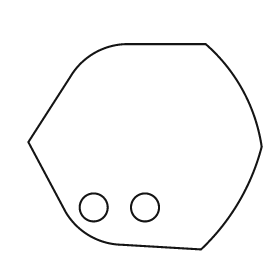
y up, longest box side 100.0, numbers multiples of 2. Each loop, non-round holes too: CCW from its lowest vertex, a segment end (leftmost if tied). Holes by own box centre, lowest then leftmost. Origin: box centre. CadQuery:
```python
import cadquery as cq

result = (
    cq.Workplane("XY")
    .moveTo(24.0, -44.0)
    .threePointArc((40.0, -24.0), (50.0, 0.0))
    .threePointArc((42.0, 24.0), (26.0, 44.0))
    .lineTo(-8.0, 44.0)
    .threePointArc((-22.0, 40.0), (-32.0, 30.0))
    .lineTo(-50.0, 2.0)
    .lineTo(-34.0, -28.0)
    .threePointArc((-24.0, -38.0), (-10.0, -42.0))
    .close()
    .moveTo(-22.0, -26.0)
    .circle(6.0)
    .moveTo(0.0, -26.0)
    .circle(6.0)
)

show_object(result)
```